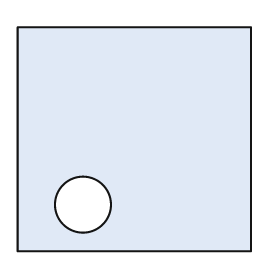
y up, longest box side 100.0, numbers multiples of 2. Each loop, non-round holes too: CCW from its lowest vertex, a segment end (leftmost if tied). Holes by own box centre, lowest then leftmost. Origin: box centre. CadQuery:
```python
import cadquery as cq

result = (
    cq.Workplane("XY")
    .moveTo(-50.0, -48.0)
    .lineTo(50.0, -48.0)
    .lineTo(50.0, 48.0)
    .lineTo(-50.0, 48.0)
    .close()
    .moveTo(-22.0, -28.0)
    .circle(12.0)
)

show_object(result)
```